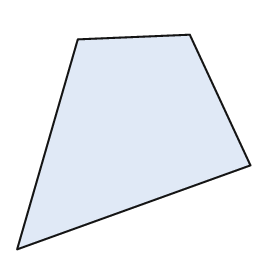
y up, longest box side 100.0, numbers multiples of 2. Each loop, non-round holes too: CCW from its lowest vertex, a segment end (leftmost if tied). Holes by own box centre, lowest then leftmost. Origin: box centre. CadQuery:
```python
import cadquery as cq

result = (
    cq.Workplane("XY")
    .moveTo(-50.0, -46.0)
    .lineTo(50.0, -10.0)
    .lineTo(24.0, 46.0)
    .lineTo(-24.0, 44.0)
    .close()
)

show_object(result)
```